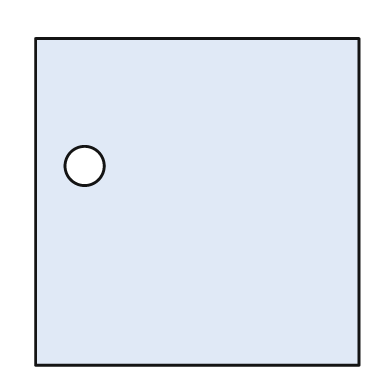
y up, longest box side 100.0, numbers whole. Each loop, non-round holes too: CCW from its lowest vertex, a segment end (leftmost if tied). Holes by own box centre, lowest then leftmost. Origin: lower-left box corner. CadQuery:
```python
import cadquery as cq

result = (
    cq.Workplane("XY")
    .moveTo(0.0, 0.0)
    .lineTo(99.0, 0.0)
    .lineTo(99.0, 100.0)
    .lineTo(0.0, 100.0)
    .close()
    .moveTo(15.0, 61.0)
    .circle(6.0)
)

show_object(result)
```